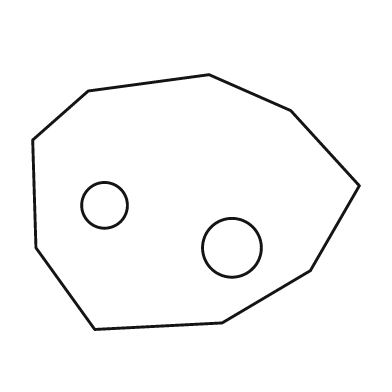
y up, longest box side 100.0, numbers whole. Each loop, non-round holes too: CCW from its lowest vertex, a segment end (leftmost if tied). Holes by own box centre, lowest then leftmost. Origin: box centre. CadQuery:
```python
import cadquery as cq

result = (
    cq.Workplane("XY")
    .moveTo(-31.0, -39.0)
    .lineTo(8.0, -37.0)
    .lineTo(35.0, -21.0)
    .lineTo(50.0, 5.0)
    .lineTo(29.0, 28.0)
    .lineTo(4.0, 39.0)
    .lineTo(-33.0, 34.0)
    .lineTo(-50.0, 19.0)
    .lineTo(-49.0, -14.0)
    .close()
    .moveTo(11.0, -14.0)
    .circle(9.0)
    .moveTo(-28.0, -1.0)
    .circle(7.0)
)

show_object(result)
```